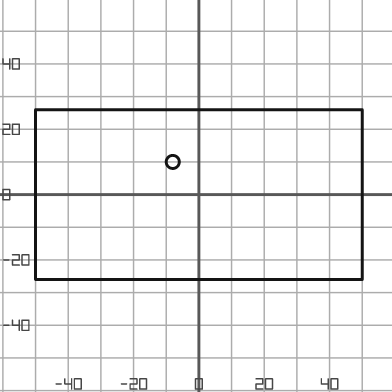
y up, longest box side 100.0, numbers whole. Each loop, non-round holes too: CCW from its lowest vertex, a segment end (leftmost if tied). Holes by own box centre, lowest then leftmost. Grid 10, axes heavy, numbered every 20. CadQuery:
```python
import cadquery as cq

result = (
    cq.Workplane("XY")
    .moveTo(-50.0, -26.0)
    .lineTo(50.0, -26.0)
    .lineTo(50.0, 26.0)
    .lineTo(-50.0, 26.0)
    .close()
    .moveTo(-8.0, 10.0)
    .circle(2.0)
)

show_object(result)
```